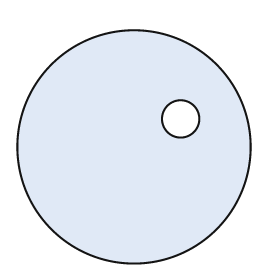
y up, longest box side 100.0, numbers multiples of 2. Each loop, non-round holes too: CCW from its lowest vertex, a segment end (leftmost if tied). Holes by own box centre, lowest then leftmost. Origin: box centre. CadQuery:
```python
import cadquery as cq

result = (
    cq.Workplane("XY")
    .moveTo(0.0, 0.0)
    .circle(50.0)
    .moveTo(20.0, 12.0)
    .circle(8.0)
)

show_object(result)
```